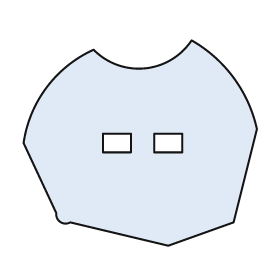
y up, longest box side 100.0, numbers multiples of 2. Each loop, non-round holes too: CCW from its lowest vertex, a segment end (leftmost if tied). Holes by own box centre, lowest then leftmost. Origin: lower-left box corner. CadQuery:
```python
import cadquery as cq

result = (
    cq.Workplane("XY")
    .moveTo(62.0, 0.0)
    .lineTo(90.0, 10.0)
    .lineTo(100.0, 50.0)
    .threePointArc((90.0, 72.0), (72.0, 88.0))
    .threePointArc((52.0, 76.0), (30.0, 84.0))
    .threePointArc((10.0, 68.0), (0.0, 44.0))
    .lineTo(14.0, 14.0)
    .threePointArc((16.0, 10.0), (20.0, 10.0))
    .close()
    .moveTo(34.0, 40.0)
    .lineTo(46.0, 40.0)
    .lineTo(46.0, 48.0)
    .lineTo(34.0, 48.0)
    .close()
    .moveTo(56.0, 40.0)
    .lineTo(68.0, 40.0)
    .lineTo(68.0, 48.0)
    .lineTo(56.0, 48.0)
    .close()
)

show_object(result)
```